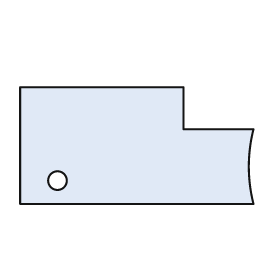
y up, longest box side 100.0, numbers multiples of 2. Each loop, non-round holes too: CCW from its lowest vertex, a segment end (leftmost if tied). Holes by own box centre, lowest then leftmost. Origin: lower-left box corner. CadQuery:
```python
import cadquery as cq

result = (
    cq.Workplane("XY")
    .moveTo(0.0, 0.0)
    .lineTo(100.0, 0.0)
    .threePointArc((98.0, 16.0), (100.0, 32.0))
    .lineTo(70.0, 32.0)
    .lineTo(70.0, 50.0)
    .lineTo(0.0, 50.0)
    .close()
    .moveTo(16.0, 10.0)
    .circle(4.0)
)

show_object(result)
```